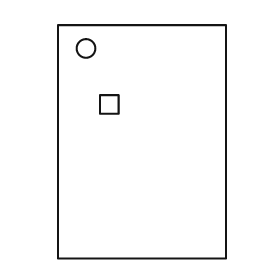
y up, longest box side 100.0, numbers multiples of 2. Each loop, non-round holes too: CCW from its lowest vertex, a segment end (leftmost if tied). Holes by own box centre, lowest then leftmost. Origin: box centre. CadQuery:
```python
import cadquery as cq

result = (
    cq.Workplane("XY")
    .moveTo(-36.0, -50.0)
    .lineTo(36.0, -50.0)
    .lineTo(36.0, 50.0)
    .lineTo(-36.0, 50.0)
    .close()
    .moveTo(-18.0, 12.0)
    .lineTo(-10.0, 12.0)
    .lineTo(-10.0, 20.0)
    .lineTo(-18.0, 20.0)
    .close()
    .moveTo(-24.0, 40.0)
    .circle(4.0)
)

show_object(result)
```